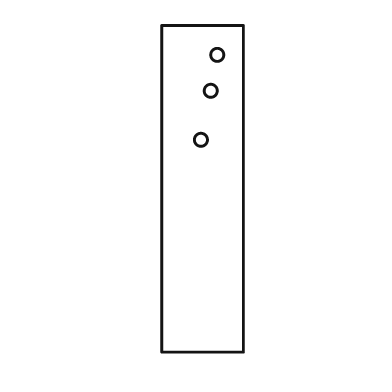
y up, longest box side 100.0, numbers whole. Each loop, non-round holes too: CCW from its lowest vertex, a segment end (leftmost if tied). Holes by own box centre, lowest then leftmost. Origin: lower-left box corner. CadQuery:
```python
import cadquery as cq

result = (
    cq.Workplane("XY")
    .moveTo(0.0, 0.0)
    .lineTo(25.0, 0.0)
    .lineTo(25.0, 100.0)
    .lineTo(0.0, 100.0)
    .close()
    .moveTo(12.0, 65.0)
    .circle(2.0)
    .moveTo(15.0, 80.0)
    .circle(2.0)
    .moveTo(17.0, 91.0)
    .circle(2.0)
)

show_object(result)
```